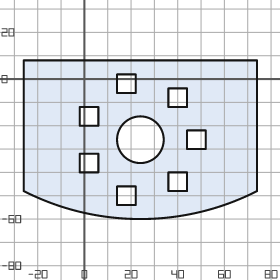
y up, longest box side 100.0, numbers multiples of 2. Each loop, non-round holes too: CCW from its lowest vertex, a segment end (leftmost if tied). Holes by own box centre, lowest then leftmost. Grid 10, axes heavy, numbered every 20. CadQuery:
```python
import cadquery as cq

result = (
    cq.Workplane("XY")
    .moveTo(-26.0, -48.0)
    .threePointArc((24.0, -60.0), (74.0, -48.0))
    .lineTo(74.0, 8.0)
    .lineTo(-26.0, 8.0)
    .close()
    .moveTo(14.0, -54.0)
    .lineTo(22.0, -54.0)
    .lineTo(22.0, -46.0)
    .lineTo(14.0, -46.0)
    .close()
    .moveTo(36.0, -48.0)
    .lineTo(44.0, -48.0)
    .lineTo(44.0, -40.0)
    .lineTo(36.0, -40.0)
    .close()
    .moveTo(-2.0, -40.0)
    .lineTo(6.0, -40.0)
    .lineTo(6.0, -32.0)
    .lineTo(-2.0, -32.0)
    .close()
    .moveTo(24.0, -26.0)
    .circle(10.0)
    .moveTo(44.0, -30.0)
    .lineTo(52.0, -30.0)
    .lineTo(52.0, -22.0)
    .lineTo(44.0, -22.0)
    .close()
    .moveTo(-2.0, -20.0)
    .lineTo(6.0, -20.0)
    .lineTo(6.0, -12.0)
    .lineTo(-2.0, -12.0)
    .close()
    .moveTo(36.0, -12.0)
    .lineTo(44.0, -12.0)
    .lineTo(44.0, -4.0)
    .lineTo(36.0, -4.0)
    .close()
    .moveTo(14.0, -6.0)
    .lineTo(22.0, -6.0)
    .lineTo(22.0, 2.0)
    .lineTo(14.0, 2.0)
    .close()
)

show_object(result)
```